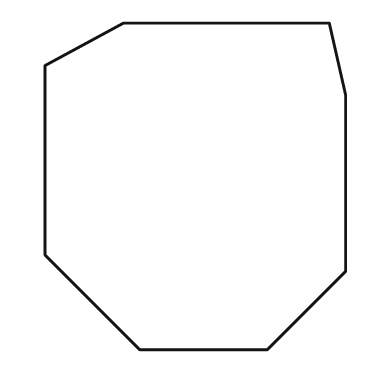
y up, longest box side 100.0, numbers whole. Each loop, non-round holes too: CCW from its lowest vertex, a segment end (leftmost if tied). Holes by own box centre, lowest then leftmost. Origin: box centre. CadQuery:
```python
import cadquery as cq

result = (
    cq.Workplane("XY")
    .moveTo(-17.0, -50.0)
    .lineTo(22.0, -50.0)
    .lineTo(46.0, -26.0)
    .lineTo(46.0, 28.0)
    .lineTo(41.0, 50.0)
    .lineTo(-22.0, 50.0)
    .lineTo(-46.0, 37.0)
    .lineTo(-46.0, -21.0)
    .close()
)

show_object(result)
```